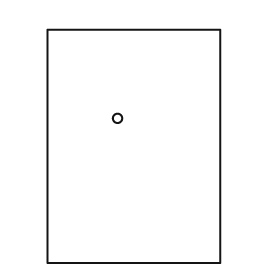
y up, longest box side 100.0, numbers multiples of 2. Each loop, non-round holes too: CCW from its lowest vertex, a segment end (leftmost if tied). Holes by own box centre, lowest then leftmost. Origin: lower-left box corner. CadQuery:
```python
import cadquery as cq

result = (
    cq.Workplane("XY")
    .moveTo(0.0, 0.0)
    .lineTo(74.0, 0.0)
    .lineTo(74.0, 100.0)
    .lineTo(0.0, 100.0)
    .close()
    .moveTo(30.0, 62.0)
    .circle(2.0)
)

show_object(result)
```